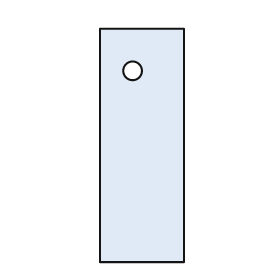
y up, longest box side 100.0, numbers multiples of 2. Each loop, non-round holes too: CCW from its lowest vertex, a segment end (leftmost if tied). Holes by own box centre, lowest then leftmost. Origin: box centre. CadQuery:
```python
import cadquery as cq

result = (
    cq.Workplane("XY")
    .moveTo(-18.0, -50.0)
    .lineTo(18.0, -50.0)
    .lineTo(18.0, 50.0)
    .lineTo(-18.0, 50.0)
    .close()
    .moveTo(-4.0, 32.0)
    .circle(4.0)
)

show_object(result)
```